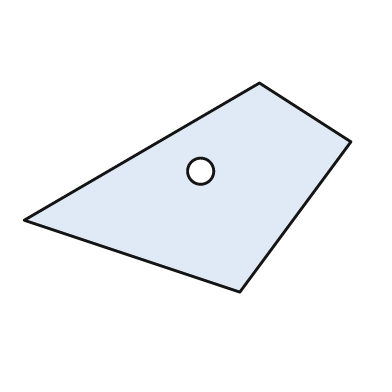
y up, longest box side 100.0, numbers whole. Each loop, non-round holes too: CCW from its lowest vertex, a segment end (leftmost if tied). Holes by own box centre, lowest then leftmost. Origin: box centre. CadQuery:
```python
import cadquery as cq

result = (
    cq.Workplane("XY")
    .moveTo(16.0, -32.0)
    .lineTo(50.0, 14.0)
    .lineTo(22.0, 32.0)
    .lineTo(-50.0, -10.0)
    .close()
    .moveTo(4.0, 5.0)
    .circle(4.0)
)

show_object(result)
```